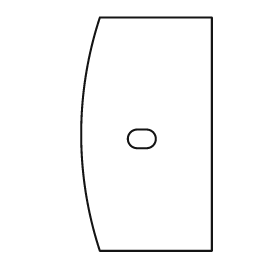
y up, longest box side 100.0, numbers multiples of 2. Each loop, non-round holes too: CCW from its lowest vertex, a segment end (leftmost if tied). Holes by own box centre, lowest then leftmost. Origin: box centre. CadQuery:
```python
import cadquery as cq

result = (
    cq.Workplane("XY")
    .moveTo(-20.0, -50.0)
    .lineTo(28.0, -50.0)
    .lineTo(28.0, 50.0)
    .lineTo(-20.0, 50.0)
    .threePointArc((-28.0, 0.0), (-20.0, -50.0))
    .close()
    .moveTo(-4.0, -6.0)
    .lineTo(0.0, -6.0)
    .threePointArc((4.0, -2.0), (0.0, 2.0))
    .lineTo(-4.0, 2.0)
    .threePointArc((-8.0, -2.0), (-4.0, -6.0))
    .close()
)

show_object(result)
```